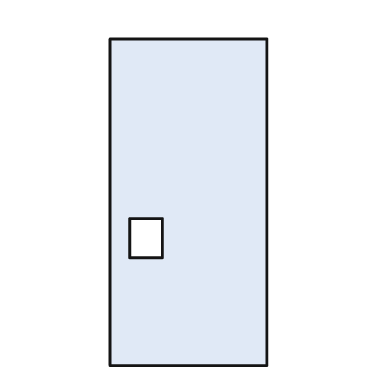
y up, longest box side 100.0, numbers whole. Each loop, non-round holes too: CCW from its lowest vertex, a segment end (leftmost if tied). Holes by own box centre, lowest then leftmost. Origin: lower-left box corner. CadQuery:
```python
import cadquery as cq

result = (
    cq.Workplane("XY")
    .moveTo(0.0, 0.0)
    .lineTo(48.0, 0.0)
    .lineTo(48.0, 100.0)
    .lineTo(0.0, 100.0)
    .close()
    .moveTo(6.0, 33.0)
    .lineTo(16.0, 33.0)
    .lineTo(16.0, 45.0)
    .lineTo(6.0, 45.0)
    .close()
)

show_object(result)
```